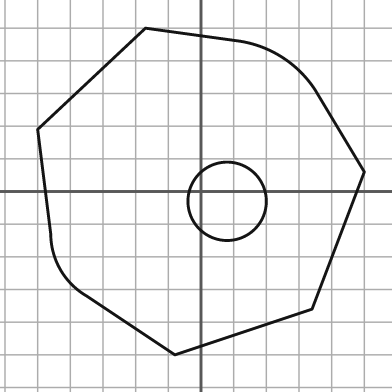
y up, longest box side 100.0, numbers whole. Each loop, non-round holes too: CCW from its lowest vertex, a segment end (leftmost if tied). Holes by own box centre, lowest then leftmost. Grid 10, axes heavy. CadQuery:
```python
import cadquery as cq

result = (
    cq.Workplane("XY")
    .moveTo(-8.0, -50.0)
    .lineTo(34.0, -36.0)
    .lineTo(50.0, 6.0)
    .lineTo(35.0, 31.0)
    .threePointArc((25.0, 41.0), (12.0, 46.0))
    .lineTo(-17.0, 50.0)
    .lineTo(-50.0, 19.0)
    .lineTo(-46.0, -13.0)
    .threePointArc((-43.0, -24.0), (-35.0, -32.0))
    .close()
    .moveTo(8.0, -3.0)
    .circle(12.0)
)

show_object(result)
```